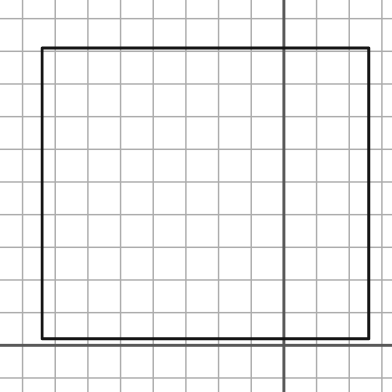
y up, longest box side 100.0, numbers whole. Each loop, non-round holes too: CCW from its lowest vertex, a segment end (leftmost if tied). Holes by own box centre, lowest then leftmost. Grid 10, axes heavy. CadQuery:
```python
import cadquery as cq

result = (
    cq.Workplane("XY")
    .moveTo(-74.0, 2.0)
    .lineTo(26.0, 2.0)
    .lineTo(26.0, 91.0)
    .lineTo(-74.0, 91.0)
    .close()
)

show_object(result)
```